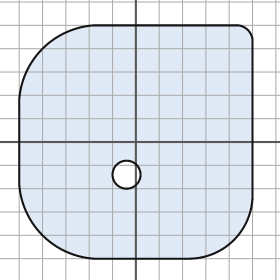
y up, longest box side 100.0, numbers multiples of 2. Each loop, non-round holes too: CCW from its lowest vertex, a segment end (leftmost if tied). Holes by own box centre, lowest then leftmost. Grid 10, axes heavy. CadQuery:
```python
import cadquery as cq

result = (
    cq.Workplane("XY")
    .moveTo(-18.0, -50.0)
    .lineTo(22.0, -50.0)
    .threePointArc((42.0, -42.0), (50.0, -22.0))
    .lineTo(50.0, 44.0)
    .threePointArc((48.0, 48.0), (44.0, 50.0))
    .lineTo(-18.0, 50.0)
    .threePointArc((-40.0, 40.0), (-50.0, 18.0))
    .lineTo(-50.0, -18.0)
    .threePointArc((-40.0, -40.0), (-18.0, -50.0))
    .close()
    .moveTo(-4.0, -14.0)
    .circle(6.0)
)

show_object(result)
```